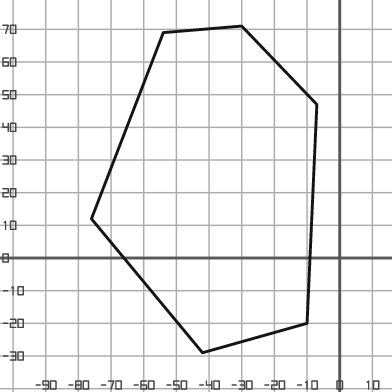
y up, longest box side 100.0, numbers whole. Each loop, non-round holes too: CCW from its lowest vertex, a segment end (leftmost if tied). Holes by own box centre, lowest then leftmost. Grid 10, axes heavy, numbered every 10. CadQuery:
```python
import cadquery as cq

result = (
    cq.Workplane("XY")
    .moveTo(-42.0, -29.0)
    .lineTo(-10.0, -20.0)
    .lineTo(-7.0, 47.0)
    .lineTo(-30.0, 71.0)
    .lineTo(-54.0, 69.0)
    .lineTo(-76.0, 12.0)
    .close()
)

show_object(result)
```